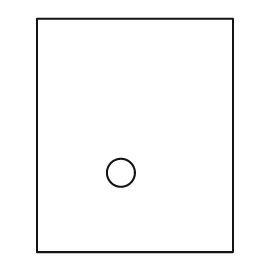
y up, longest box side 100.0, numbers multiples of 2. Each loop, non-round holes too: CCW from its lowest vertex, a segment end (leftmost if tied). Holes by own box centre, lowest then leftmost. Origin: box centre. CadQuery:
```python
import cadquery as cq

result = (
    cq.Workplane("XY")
    .moveTo(-42.0, -50.0)
    .lineTo(42.0, -50.0)
    .lineTo(42.0, 50.0)
    .lineTo(-42.0, 50.0)
    .close()
    .moveTo(-6.0, -16.0)
    .circle(6.0)
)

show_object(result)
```